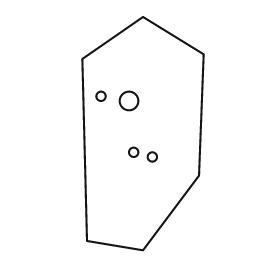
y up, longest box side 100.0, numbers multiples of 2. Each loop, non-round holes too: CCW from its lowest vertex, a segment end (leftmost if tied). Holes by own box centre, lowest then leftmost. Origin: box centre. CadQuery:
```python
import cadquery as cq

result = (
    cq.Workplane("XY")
    .moveTo(0.0, -50.0)
    .lineTo(24.0, -18.0)
    .lineTo(26.0, 34.0)
    .lineTo(0.0, 50.0)
    .lineTo(-26.0, 32.0)
    .lineTo(-24.0, -46.0)
    .close()
    .moveTo(4.0, -10.0)
    .circle(2.0)
    .moveTo(-4.0, -8.0)
    .circle(2.0)
    .moveTo(-6.0, 14.0)
    .circle(4.0)
    .moveTo(-18.0, 16.0)
    .circle(2.0)
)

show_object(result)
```